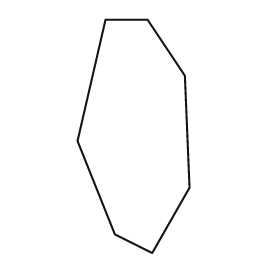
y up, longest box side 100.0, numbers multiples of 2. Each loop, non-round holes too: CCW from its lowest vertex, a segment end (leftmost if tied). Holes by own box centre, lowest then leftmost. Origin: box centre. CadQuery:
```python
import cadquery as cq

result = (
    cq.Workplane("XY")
    .moveTo(8.0, -50.0)
    .lineTo(24.0, -22.0)
    .lineTo(22.0, 26.0)
    .lineTo(6.0, 50.0)
    .lineTo(-12.0, 50.0)
    .lineTo(-24.0, -2.0)
    .lineTo(-8.0, -42.0)
    .close()
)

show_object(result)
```